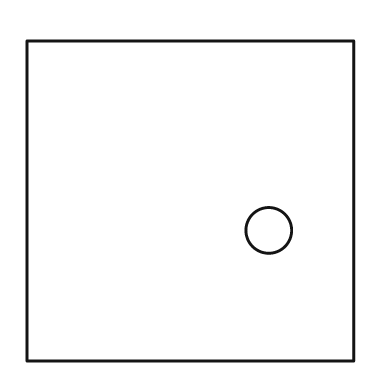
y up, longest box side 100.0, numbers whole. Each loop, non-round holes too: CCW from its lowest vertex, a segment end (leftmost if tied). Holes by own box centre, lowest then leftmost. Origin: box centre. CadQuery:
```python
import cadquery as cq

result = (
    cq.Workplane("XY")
    .moveTo(-50.0, -49.0)
    .lineTo(50.0, -49.0)
    .lineTo(50.0, 49.0)
    .lineTo(-50.0, 49.0)
    .close()
    .moveTo(24.0, -9.0)
    .circle(7.0)
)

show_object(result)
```